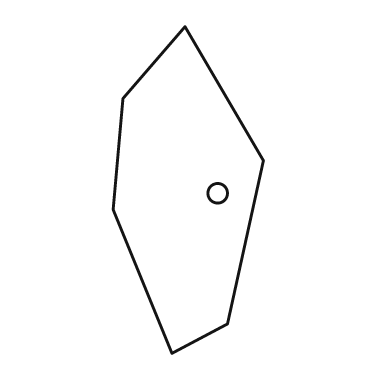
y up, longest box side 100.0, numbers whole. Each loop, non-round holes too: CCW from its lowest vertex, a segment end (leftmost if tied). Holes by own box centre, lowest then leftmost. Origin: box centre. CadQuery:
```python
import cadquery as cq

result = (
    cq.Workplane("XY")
    .moveTo(-5.0, -50.0)
    .lineTo(12.0, -41.0)
    .lineTo(23.0, 9.0)
    .lineTo(-1.0, 50.0)
    .lineTo(-20.0, 28.0)
    .lineTo(-23.0, -6.0)
    .close()
    .moveTo(9.0, -1.0)
    .circle(3.0)
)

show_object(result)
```